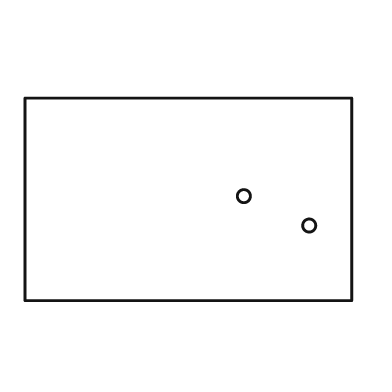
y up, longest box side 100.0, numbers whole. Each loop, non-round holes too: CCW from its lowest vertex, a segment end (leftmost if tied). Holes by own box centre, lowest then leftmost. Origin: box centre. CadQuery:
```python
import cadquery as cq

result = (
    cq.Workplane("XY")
    .moveTo(-50.0, -31.0)
    .lineTo(50.0, -31.0)
    .lineTo(50.0, 31.0)
    .lineTo(-50.0, 31.0)
    .close()
    .moveTo(37.0, -8.0)
    .circle(2.0)
    .moveTo(17.0, 1.0)
    .circle(2.0)
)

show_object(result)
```